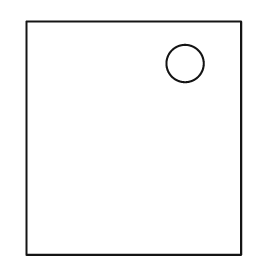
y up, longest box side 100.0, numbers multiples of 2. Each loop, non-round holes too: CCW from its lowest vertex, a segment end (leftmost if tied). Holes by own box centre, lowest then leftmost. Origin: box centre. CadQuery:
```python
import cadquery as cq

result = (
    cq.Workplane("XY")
    .moveTo(-46.0, -50.0)
    .lineTo(46.0, -50.0)
    .lineTo(46.0, 50.0)
    .lineTo(-46.0, 50.0)
    .close()
    .moveTo(22.0, 32.0)
    .circle(8.0)
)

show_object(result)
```